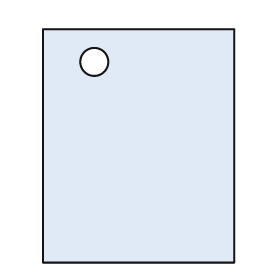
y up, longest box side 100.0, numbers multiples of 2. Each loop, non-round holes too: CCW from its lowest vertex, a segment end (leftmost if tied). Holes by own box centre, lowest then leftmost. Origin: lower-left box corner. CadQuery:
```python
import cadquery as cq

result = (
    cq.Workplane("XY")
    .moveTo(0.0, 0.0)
    .lineTo(82.0, 0.0)
    .lineTo(82.0, 100.0)
    .lineTo(0.0, 100.0)
    .close()
    .moveTo(22.0, 86.0)
    .circle(6.0)
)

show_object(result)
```